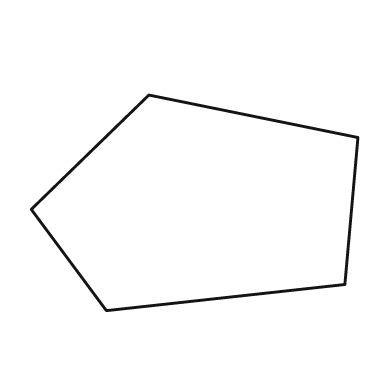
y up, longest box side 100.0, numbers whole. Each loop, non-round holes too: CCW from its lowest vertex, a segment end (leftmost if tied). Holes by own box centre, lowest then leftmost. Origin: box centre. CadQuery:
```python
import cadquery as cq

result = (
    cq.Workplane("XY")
    .moveTo(-27.0, -33.0)
    .lineTo(46.0, -25.0)
    .lineTo(50.0, 20.0)
    .lineTo(-14.0, 33.0)
    .lineTo(-50.0, -2.0)
    .close()
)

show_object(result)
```